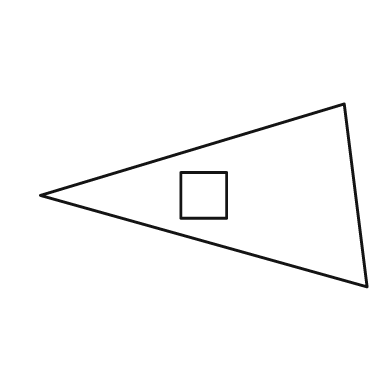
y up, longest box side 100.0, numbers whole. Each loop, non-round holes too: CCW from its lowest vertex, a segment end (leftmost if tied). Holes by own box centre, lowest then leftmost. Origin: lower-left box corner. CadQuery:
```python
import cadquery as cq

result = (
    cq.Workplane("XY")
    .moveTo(100.0, 0.0)
    .lineTo(93.0, 56.0)
    .lineTo(0.0, 28.0)
    .close()
    .moveTo(43.0, 21.0)
    .lineTo(57.0, 21.0)
    .lineTo(57.0, 35.0)
    .lineTo(43.0, 35.0)
    .close()
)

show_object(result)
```